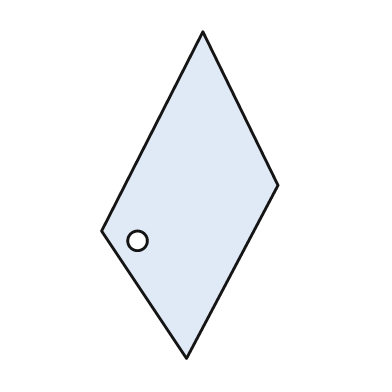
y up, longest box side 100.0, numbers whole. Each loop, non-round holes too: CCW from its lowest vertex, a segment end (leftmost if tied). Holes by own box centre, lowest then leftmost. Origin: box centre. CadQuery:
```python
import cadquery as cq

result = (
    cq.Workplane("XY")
    .moveTo(-1.0, -50.0)
    .lineTo(27.0, 3.0)
    .lineTo(4.0, 50.0)
    .lineTo(-27.0, -11.0)
    .close()
    .moveTo(-16.0, -14.0)
    .circle(3.0)
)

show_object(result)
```